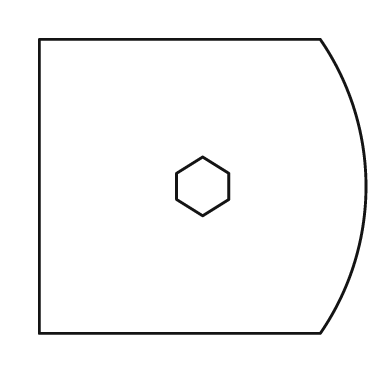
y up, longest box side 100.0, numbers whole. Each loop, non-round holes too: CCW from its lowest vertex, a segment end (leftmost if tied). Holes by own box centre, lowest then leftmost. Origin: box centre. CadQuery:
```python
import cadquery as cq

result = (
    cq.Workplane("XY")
    .moveTo(-50.0, -45.0)
    .lineTo(36.0, -45.0)
    .threePointArc((50.0, 0.0), (36.0, 45.0))
    .lineTo(-50.0, 45.0)
    .close()
    .moveTo(0.0, -9.0)
    .lineTo(8.0, -4.0)
    .lineTo(8.0, 4.0)
    .lineTo(0.0, 9.0)
    .lineTo(-8.0, 4.0)
    .lineTo(-8.0, -4.0)
    .close()
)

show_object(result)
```